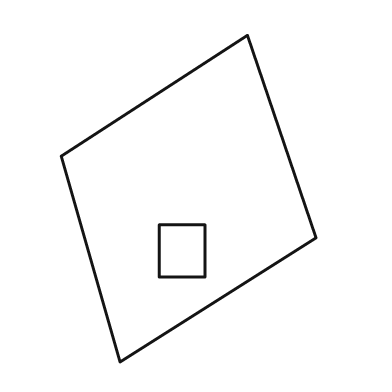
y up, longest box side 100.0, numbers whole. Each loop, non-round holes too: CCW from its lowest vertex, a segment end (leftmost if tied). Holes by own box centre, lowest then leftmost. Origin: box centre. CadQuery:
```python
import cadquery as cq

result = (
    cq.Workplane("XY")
    .moveTo(-21.0, -50.0)
    .lineTo(39.0, -12.0)
    .lineTo(18.0, 50.0)
    .lineTo(-39.0, 13.0)
    .close()
    .moveTo(-9.0, -24.0)
    .lineTo(5.0, -24.0)
    .lineTo(5.0, -8.0)
    .lineTo(-9.0, -8.0)
    .close()
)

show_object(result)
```